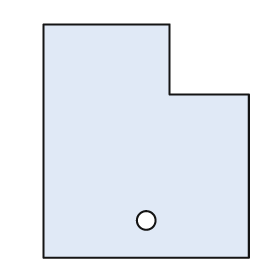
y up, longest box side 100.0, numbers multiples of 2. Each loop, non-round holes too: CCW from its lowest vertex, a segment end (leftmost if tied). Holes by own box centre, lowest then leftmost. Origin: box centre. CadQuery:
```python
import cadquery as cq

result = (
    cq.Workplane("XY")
    .moveTo(-44.0, -50.0)
    .lineTo(44.0, -50.0)
    .lineTo(44.0, 20.0)
    .lineTo(10.0, 20.0)
    .lineTo(10.0, 50.0)
    .lineTo(-44.0, 50.0)
    .close()
    .moveTo(0.0, -34.0)
    .circle(4.0)
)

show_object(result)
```